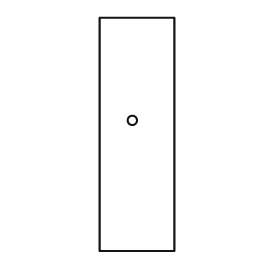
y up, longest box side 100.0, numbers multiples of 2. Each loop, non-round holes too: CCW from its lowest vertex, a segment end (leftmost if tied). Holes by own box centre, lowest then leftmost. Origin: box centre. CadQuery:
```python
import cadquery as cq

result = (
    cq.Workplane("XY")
    .moveTo(-16.0, -50.0)
    .lineTo(16.0, -50.0)
    .lineTo(16.0, 50.0)
    .lineTo(-16.0, 50.0)
    .close()
    .moveTo(-2.0, 6.0)
    .circle(2.0)
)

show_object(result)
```